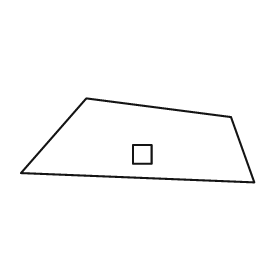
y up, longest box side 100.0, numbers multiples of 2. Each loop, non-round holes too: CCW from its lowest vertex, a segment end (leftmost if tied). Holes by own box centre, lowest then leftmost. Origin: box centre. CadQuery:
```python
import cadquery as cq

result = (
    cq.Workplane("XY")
    .moveTo(50.0, -18.0)
    .lineTo(40.0, 10.0)
    .lineTo(-22.0, 18.0)
    .lineTo(-50.0, -14.0)
    .close()
    .moveTo(-2.0, -10.0)
    .lineTo(6.0, -10.0)
    .lineTo(6.0, -2.0)
    .lineTo(-2.0, -2.0)
    .close()
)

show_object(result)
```